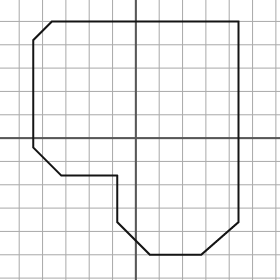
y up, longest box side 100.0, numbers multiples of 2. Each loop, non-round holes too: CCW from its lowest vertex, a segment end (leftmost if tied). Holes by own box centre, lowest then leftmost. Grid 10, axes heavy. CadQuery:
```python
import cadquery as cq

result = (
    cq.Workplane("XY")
    .moveTo(6.0, -50.0)
    .lineTo(28.0, -50.0)
    .lineTo(44.0, -36.0)
    .lineTo(44.0, 50.0)
    .lineTo(-36.0, 50.0)
    .lineTo(-44.0, 42.0)
    .lineTo(-44.0, -4.0)
    .lineTo(-32.0, -16.0)
    .lineTo(-8.0, -16.0)
    .lineTo(-8.0, -36.0)
    .close()
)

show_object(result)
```